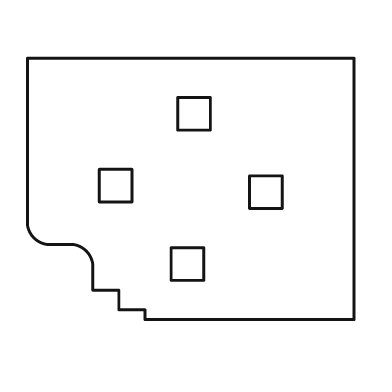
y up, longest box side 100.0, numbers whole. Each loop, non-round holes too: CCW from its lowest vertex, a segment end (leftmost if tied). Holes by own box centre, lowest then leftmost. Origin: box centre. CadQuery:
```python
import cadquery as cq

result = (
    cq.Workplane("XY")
    .moveTo(-14.0, -40.0)
    .lineTo(50.0, -40.0)
    .lineTo(50.0, 40.0)
    .lineTo(-50.0, 40.0)
    .lineTo(-50.0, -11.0)
    .threePointArc((-48.0, -15.0), (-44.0, -17.0))
    .lineTo(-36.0, -17.0)
    .threePointArc((-32.0, -19.0), (-30.0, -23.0))
    .lineTo(-30.0, -31.0)
    .lineTo(-22.0, -31.0)
    .lineTo(-22.0, -37.0)
    .lineTo(-14.0, -37.0)
    .close()
    .moveTo(-6.0, -28.0)
    .lineTo(4.0, -28.0)
    .lineTo(4.0, -18.0)
    .lineTo(-6.0, -18.0)
    .close()
    .moveTo(18.0, -6.0)
    .lineTo(28.0, -6.0)
    .lineTo(28.0, 4.0)
    .lineTo(18.0, 4.0)
    .close()
    .moveTo(-28.0, -4.0)
    .lineTo(-18.0, -4.0)
    .lineTo(-18.0, 6.0)
    .lineTo(-28.0, 6.0)
    .close()
    .moveTo(-4.0, 18.0)
    .lineTo(6.0, 18.0)
    .lineTo(6.0, 28.0)
    .lineTo(-4.0, 28.0)
    .close()
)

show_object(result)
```